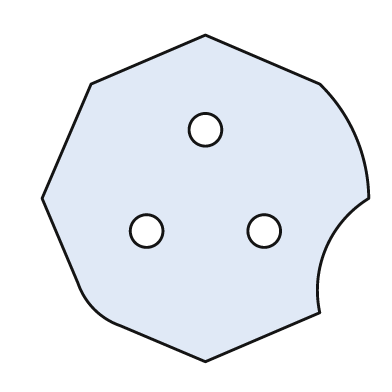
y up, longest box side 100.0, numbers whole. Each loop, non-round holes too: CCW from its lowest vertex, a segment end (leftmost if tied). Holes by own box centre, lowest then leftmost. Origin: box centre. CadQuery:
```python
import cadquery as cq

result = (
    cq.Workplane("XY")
    .moveTo(0.0, -50.0)
    .lineTo(35.0, -35.0)
    .threePointArc((37.0, -15.0), (50.0, 0.0))
    .threePointArc((46.0, 19.0), (35.0, 35.0))
    .lineTo(0.0, 50.0)
    .lineTo(-35.0, 35.0)
    .lineTo(-50.0, 0.0)
    .lineTo(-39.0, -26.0)
    .threePointArc((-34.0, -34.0), (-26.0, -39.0))
    .close()
    .moveTo(-18.0, -10.0)
    .circle(5.0)
    .moveTo(18.0, -10.0)
    .circle(5.0)
    .moveTo(0.0, 21.0)
    .circle(5.0)
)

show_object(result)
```